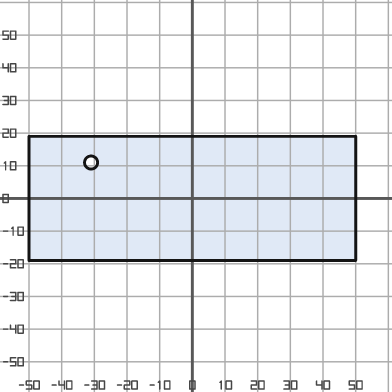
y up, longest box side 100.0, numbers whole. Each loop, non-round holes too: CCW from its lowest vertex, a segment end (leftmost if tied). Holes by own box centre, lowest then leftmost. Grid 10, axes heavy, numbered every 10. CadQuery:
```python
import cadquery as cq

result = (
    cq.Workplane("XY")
    .moveTo(-50.0, -19.0)
    .lineTo(50.0, -19.0)
    .lineTo(50.0, 19.0)
    .lineTo(-50.0, 19.0)
    .close()
    .moveTo(-31.0, 11.0)
    .circle(2.0)
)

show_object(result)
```